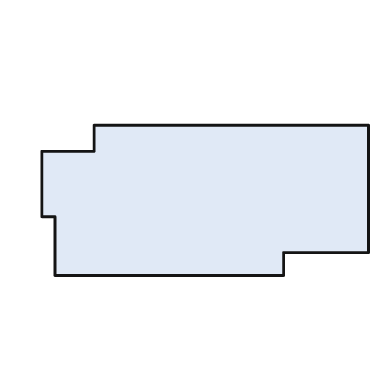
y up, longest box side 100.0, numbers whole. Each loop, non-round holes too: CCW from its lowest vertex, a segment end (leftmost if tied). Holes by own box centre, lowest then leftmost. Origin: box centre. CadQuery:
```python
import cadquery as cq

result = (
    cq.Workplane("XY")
    .moveTo(-46.0, -23.0)
    .lineTo(24.0, -23.0)
    .lineTo(24.0, -16.0)
    .lineTo(50.0, -16.0)
    .lineTo(50.0, 23.0)
    .lineTo(-34.0, 23.0)
    .lineTo(-34.0, 15.0)
    .lineTo(-50.0, 15.0)
    .lineTo(-50.0, -5.0)
    .lineTo(-46.0, -5.0)
    .close()
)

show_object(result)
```